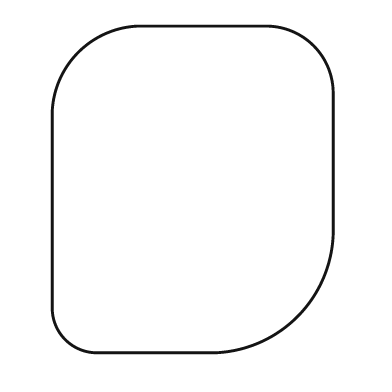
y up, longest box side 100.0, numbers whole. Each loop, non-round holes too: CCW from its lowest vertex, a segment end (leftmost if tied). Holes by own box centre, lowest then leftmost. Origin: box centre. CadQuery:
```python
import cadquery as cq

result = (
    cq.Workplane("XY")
    .moveTo(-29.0, -50.0)
    .lineTo(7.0, -50.0)
    .threePointArc((32.0, -39.0), (43.0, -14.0))
    .lineTo(43.0, 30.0)
    .threePointArc((37.0, 44.0), (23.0, 50.0))
    .lineTo(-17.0, 50.0)
    .threePointArc((-35.0, 42.0), (-43.0, 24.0))
    .lineTo(-43.0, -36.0)
    .threePointArc((-39.0, -46.0), (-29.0, -50.0))
    .close()
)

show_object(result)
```